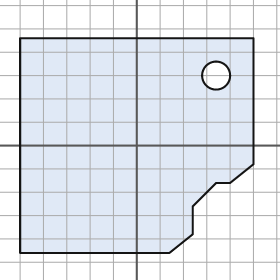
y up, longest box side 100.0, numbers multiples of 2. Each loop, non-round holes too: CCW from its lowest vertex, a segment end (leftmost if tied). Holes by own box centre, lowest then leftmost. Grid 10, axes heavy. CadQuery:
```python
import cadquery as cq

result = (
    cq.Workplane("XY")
    .moveTo(-50.0, -46.0)
    .lineTo(14.0, -46.0)
    .lineTo(24.0, -38.0)
    .lineTo(24.0, -26.0)
    .lineTo(34.0, -16.0)
    .lineTo(40.0, -16.0)
    .lineTo(50.0, -8.0)
    .lineTo(50.0, 46.0)
    .lineTo(-50.0, 46.0)
    .close()
    .moveTo(34.0, 30.0)
    .circle(6.0)
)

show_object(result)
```